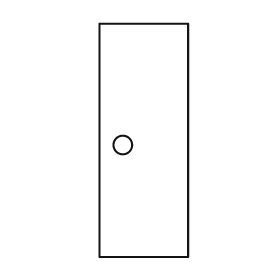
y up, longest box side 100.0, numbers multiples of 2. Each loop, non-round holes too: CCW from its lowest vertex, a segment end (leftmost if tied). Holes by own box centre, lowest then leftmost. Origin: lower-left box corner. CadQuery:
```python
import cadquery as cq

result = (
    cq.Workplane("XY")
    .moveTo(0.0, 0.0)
    .lineTo(38.0, 0.0)
    .lineTo(38.0, 100.0)
    .lineTo(0.0, 100.0)
    .close()
    .moveTo(10.0, 48.0)
    .circle(4.0)
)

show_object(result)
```